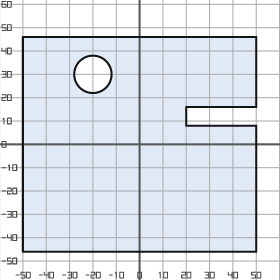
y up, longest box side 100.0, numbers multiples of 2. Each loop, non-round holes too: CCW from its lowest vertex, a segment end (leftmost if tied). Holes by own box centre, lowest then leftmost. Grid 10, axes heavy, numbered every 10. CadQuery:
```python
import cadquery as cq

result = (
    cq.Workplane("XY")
    .moveTo(-50.0, -46.0)
    .lineTo(50.0, -46.0)
    .lineTo(50.0, 8.0)
    .lineTo(20.0, 8.0)
    .lineTo(20.0, 16.0)
    .lineTo(50.0, 16.0)
    .lineTo(50.0, 46.0)
    .lineTo(-50.0, 46.0)
    .close()
    .moveTo(-20.0, 30.0)
    .circle(8.0)
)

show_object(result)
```